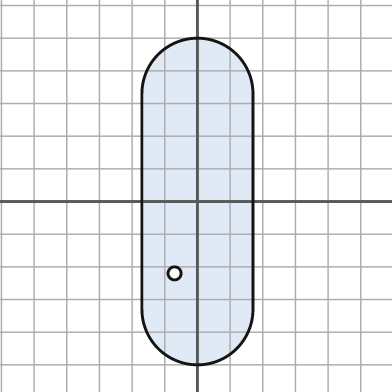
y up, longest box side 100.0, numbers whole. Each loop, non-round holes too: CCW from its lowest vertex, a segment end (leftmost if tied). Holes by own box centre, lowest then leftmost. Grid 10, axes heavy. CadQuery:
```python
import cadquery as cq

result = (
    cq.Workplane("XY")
    .moveTo(-17.0, -33.0)
    .threePointArc((0.0, -50.0), (17.0, -33.0))
    .lineTo(17.0, 33.0)
    .threePointArc((0.0, 50.0), (-17.0, 33.0))
    .close()
    .moveTo(-7.0, -22.0)
    .circle(2.0)
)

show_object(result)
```